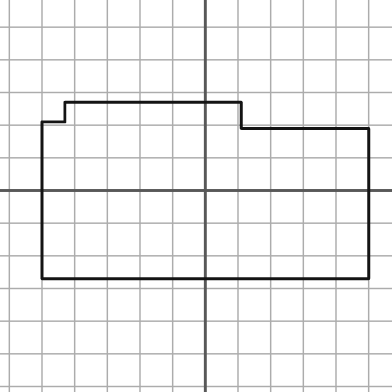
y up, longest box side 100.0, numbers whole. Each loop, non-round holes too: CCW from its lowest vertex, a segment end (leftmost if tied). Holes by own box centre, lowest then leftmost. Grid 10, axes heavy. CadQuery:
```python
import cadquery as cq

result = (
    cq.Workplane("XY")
    .moveTo(-50.0, -27.0)
    .lineTo(50.0, -27.0)
    .lineTo(50.0, 19.0)
    .lineTo(11.0, 19.0)
    .lineTo(11.0, 27.0)
    .lineTo(-43.0, 27.0)
    .lineTo(-43.0, 21.0)
    .lineTo(-50.0, 21.0)
    .close()
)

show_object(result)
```